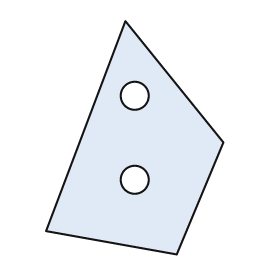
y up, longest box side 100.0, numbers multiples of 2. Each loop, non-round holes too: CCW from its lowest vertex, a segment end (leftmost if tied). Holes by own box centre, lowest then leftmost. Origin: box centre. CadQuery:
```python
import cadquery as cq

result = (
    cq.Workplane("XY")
    .moveTo(18.0, -50.0)
    .lineTo(38.0, -2.0)
    .lineTo(-4.0, 50.0)
    .lineTo(-38.0, -40.0)
    .close()
    .moveTo(0.0, -18.0)
    .circle(6.0)
    .moveTo(0.0, 18.0)
    .circle(6.0)
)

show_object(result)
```